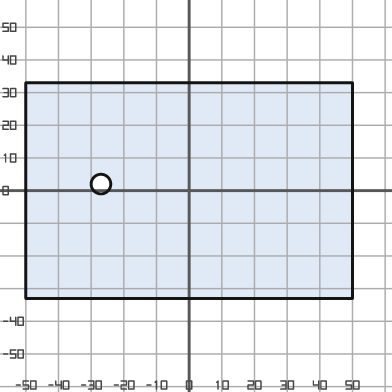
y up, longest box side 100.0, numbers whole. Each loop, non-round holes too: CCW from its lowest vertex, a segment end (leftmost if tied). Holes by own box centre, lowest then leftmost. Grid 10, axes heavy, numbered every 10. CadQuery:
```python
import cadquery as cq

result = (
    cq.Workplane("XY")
    .moveTo(-50.0, -33.0)
    .lineTo(50.0, -33.0)
    .lineTo(50.0, 33.0)
    .lineTo(-50.0, 33.0)
    .close()
    .moveTo(-27.0, 2.0)
    .circle(3.0)
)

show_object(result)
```